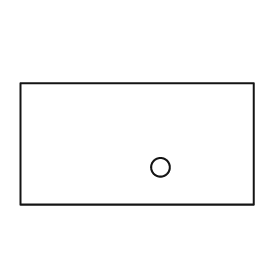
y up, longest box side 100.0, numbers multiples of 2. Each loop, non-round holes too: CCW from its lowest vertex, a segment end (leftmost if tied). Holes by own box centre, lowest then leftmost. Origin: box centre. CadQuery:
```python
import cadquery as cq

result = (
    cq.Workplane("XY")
    .moveTo(-50.0, -26.0)
    .lineTo(50.0, -26.0)
    .lineTo(50.0, 26.0)
    .lineTo(-50.0, 26.0)
    .close()
    .moveTo(10.0, -10.0)
    .circle(4.0)
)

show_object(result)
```